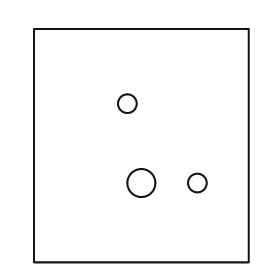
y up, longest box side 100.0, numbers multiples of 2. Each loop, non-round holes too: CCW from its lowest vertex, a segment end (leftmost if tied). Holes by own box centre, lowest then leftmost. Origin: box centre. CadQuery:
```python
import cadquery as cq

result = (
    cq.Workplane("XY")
    .moveTo(-46.0, -50.0)
    .lineTo(46.0, -50.0)
    .lineTo(46.0, 50.0)
    .lineTo(-46.0, 50.0)
    .close()
    .moveTo(0.0, -16.0)
    .circle(6.0)
    .moveTo(24.0, -16.0)
    .circle(4.0)
    .moveTo(-6.0, 18.0)
    .circle(4.0)
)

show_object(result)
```